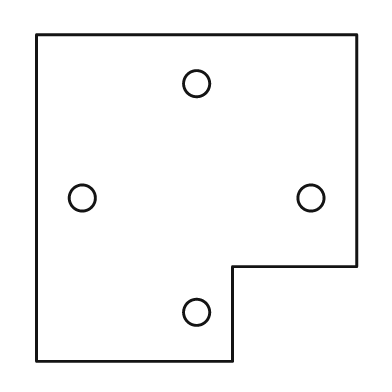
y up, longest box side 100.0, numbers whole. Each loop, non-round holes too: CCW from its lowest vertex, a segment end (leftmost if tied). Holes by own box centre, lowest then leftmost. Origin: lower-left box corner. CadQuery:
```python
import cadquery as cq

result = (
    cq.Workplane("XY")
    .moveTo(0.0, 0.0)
    .lineTo(60.0, 0.0)
    .lineTo(60.0, 29.0)
    .lineTo(98.0, 29.0)
    .lineTo(98.0, 100.0)
    .lineTo(0.0, 100.0)
    .close()
    .moveTo(49.0, 15.0)
    .circle(4.0)
    .moveTo(14.0, 50.0)
    .circle(4.0)
    .moveTo(84.0, 50.0)
    .circle(4.0)
    .moveTo(49.0, 85.0)
    .circle(4.0)
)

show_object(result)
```